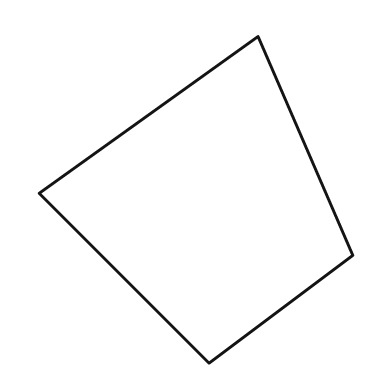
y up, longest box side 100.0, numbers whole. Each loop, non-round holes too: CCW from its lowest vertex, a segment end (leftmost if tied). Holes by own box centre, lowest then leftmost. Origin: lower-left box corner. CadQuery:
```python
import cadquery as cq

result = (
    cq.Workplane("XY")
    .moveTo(52.0, 0.0)
    .lineTo(96.0, 33.0)
    .lineTo(67.0, 100.0)
    .lineTo(0.0, 52.0)
    .close()
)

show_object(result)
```